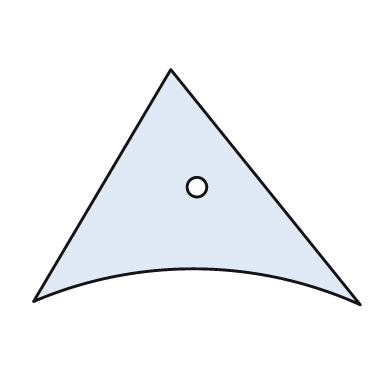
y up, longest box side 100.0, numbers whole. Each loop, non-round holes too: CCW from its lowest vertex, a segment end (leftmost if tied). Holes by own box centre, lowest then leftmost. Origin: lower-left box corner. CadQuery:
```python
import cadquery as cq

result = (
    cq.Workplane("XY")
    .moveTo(100.0, 0.0)
    .lineTo(42.0, 72.0)
    .lineTo(0.0, 1.0)
    .threePointArc((50.0, 11.0), (100.0, 0.0))
    .close()
    .moveTo(50.0, 36.0)
    .circle(3.0)
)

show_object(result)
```